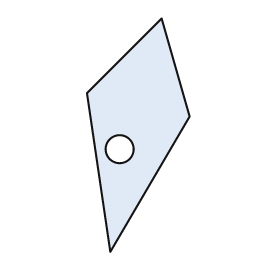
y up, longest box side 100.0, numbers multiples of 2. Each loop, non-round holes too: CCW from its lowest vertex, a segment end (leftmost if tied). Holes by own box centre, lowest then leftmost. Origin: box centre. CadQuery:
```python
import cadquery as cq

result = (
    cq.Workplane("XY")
    .moveTo(-12.0, -50.0)
    .lineTo(22.0, 8.0)
    .lineTo(10.0, 50.0)
    .lineTo(-22.0, 18.0)
    .close()
    .moveTo(-8.0, -6.0)
    .circle(6.0)
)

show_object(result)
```